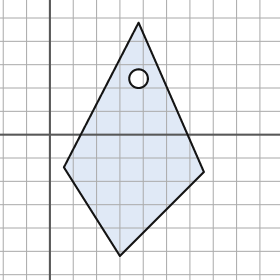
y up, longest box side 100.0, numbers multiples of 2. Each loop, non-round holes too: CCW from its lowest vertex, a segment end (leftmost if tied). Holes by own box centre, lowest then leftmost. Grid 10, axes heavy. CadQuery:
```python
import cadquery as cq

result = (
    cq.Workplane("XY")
    .moveTo(30.0, -52.0)
    .lineTo(66.0, -16.0)
    .lineTo(38.0, 48.0)
    .lineTo(6.0, -14.0)
    .close()
    .moveTo(38.0, 24.0)
    .circle(4.0)
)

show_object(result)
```